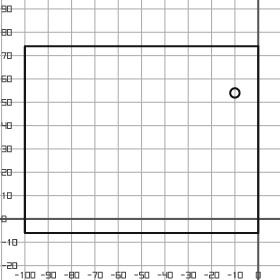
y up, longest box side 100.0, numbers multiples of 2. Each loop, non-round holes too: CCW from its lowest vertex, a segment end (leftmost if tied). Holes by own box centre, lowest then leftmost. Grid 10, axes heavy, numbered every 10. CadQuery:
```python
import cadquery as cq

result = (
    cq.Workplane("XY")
    .moveTo(-100.0, -6.0)
    .lineTo(0.0, -6.0)
    .lineTo(0.0, 74.0)
    .lineTo(-100.0, 74.0)
    .close()
    .moveTo(-10.0, 54.0)
    .circle(2.0)
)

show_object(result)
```